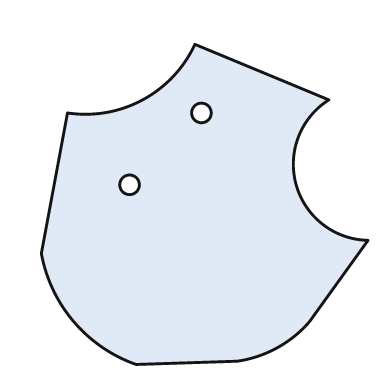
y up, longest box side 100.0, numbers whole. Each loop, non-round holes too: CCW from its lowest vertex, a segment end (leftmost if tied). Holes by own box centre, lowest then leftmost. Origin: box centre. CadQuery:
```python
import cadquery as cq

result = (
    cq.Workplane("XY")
    .moveTo(-21.0, -49.0)
    .lineTo(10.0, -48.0)
    .threePointArc((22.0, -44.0), (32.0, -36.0))
    .lineTo(50.0, -11.0)
    .threePointArc((28.0, 6.0), (38.0, 32.0))
    .lineTo(-3.0, 49.0)
    .threePointArc((-19.0, 32.0), (-42.0, 28.0))
    .lineTo(-50.0, -15.0)
    .threePointArc((-40.0, -36.0), (-21.0, -49.0))
    .close()
    .moveTo(-23.0, 6.0)
    .circle(3.0)
    .moveTo(-1.0, 28.0)
    .circle(3.0)
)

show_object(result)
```